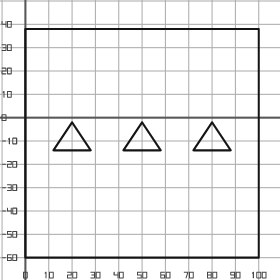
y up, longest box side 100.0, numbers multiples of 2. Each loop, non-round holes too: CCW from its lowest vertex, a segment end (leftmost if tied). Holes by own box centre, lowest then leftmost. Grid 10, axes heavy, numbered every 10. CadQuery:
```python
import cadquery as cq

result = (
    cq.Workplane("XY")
    .moveTo(0.0, -60.0)
    .lineTo(100.0, -60.0)
    .lineTo(100.0, 38.0)
    .lineTo(0.0, 38.0)
    .close()
    .moveTo(12.0, -14.0)
    .lineTo(28.0, -14.0)
    .lineTo(20.0, -2.0)
    .close()
    .moveTo(42.0, -14.0)
    .lineTo(58.0, -14.0)
    .lineTo(50.0, -2.0)
    .close()
    .moveTo(72.0, -14.0)
    .lineTo(88.0, -14.0)
    .lineTo(80.0, -2.0)
    .close()
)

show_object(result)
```